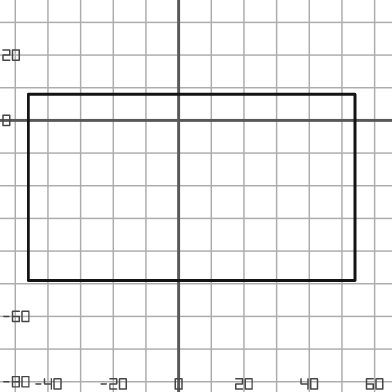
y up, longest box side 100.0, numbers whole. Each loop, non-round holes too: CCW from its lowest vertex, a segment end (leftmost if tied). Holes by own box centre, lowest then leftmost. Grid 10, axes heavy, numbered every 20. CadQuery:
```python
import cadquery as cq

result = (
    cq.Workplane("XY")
    .moveTo(-46.0, -49.0)
    .lineTo(54.0, -49.0)
    .lineTo(54.0, 8.0)
    .lineTo(-46.0, 8.0)
    .close()
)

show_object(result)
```